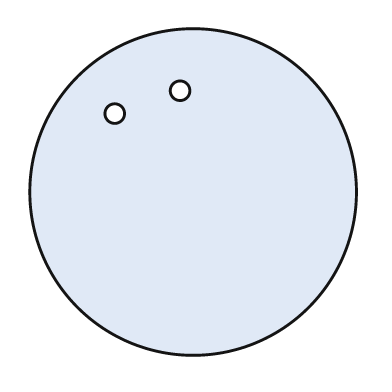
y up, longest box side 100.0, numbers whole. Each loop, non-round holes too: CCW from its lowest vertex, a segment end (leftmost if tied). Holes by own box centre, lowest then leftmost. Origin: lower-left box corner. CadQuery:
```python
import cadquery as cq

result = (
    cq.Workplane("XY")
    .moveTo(50.0, 50.0)
    .circle(50.0)
    .moveTo(26.0, 74.0)
    .circle(3.0)
    .moveTo(46.0, 81.0)
    .circle(3.0)
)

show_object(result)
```